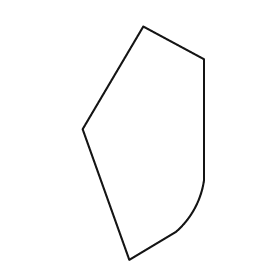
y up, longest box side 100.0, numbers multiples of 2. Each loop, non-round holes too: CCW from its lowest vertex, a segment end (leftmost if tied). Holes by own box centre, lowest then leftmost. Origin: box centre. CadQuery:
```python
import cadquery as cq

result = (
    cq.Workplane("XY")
    .moveTo(-6.0, -50.0)
    .lineTo(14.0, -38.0)
    .threePointArc((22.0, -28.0), (26.0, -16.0))
    .lineTo(26.0, 36.0)
    .lineTo(0.0, 50.0)
    .lineTo(-26.0, 6.0)
    .close()
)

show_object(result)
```